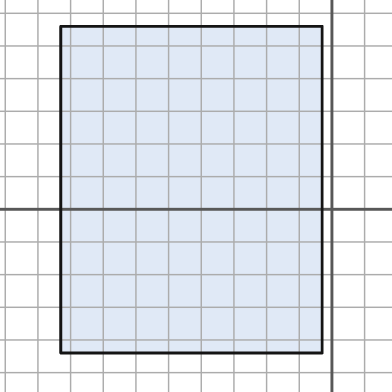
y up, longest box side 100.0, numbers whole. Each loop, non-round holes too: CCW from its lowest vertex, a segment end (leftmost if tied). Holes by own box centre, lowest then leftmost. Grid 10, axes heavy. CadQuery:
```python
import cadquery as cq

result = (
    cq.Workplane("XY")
    .moveTo(-83.0, -44.0)
    .lineTo(-3.0, -44.0)
    .lineTo(-3.0, 56.0)
    .lineTo(-83.0, 56.0)
    .close()
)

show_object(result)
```